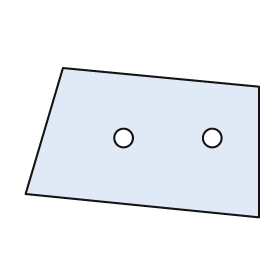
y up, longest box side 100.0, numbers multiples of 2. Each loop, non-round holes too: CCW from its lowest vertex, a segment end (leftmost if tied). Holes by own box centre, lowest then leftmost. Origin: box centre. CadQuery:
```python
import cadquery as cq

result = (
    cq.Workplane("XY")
    .moveTo(50.0, -32.0)
    .lineTo(50.0, 24.0)
    .lineTo(-34.0, 32.0)
    .lineTo(-50.0, -22.0)
    .close()
    .moveTo(-8.0, 2.0)
    .circle(4.0)
    .moveTo(30.0, 2.0)
    .circle(4.0)
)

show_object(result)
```